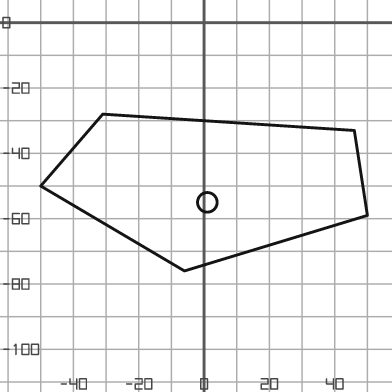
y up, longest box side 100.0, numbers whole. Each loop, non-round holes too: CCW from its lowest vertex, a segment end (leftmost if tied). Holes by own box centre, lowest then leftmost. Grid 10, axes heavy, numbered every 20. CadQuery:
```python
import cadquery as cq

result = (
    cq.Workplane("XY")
    .moveTo(-6.0, -76.0)
    .lineTo(50.0, -59.0)
    .lineTo(46.0, -33.0)
    .lineTo(-31.0, -28.0)
    .lineTo(-50.0, -50.0)
    .close()
    .moveTo(1.0, -55.0)
    .circle(3.0)
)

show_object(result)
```